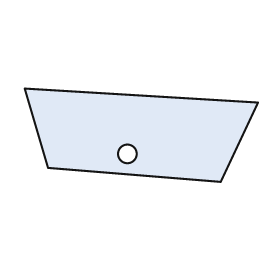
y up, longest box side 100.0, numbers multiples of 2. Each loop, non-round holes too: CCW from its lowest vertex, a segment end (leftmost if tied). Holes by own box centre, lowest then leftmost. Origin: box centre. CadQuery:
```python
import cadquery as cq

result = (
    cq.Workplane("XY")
    .moveTo(34.0, -20.0)
    .lineTo(50.0, 14.0)
    .lineTo(-50.0, 20.0)
    .lineTo(-40.0, -14.0)
    .close()
    .moveTo(-6.0, -8.0)
    .circle(4.0)
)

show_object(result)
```